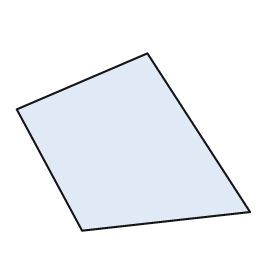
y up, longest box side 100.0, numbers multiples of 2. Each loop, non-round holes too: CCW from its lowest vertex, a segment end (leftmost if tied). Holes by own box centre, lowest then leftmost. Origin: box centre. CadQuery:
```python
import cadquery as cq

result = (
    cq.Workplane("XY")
    .moveTo(-22.0, -38.0)
    .lineTo(50.0, -30.0)
    .lineTo(6.0, 38.0)
    .lineTo(-50.0, 14.0)
    .close()
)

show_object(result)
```